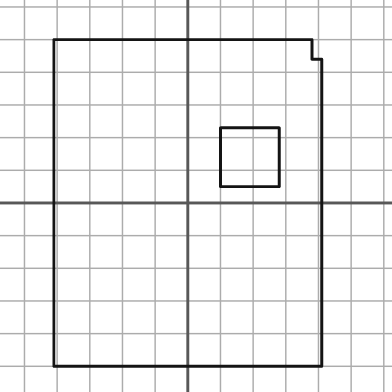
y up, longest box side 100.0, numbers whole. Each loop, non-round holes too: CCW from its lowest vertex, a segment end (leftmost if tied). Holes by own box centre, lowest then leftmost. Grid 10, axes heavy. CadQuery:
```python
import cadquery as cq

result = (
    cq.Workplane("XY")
    .moveTo(-41.0, -50.0)
    .lineTo(41.0, -50.0)
    .lineTo(41.0, 44.0)
    .lineTo(38.0, 44.0)
    .lineTo(38.0, 50.0)
    .lineTo(-41.0, 50.0)
    .close()
    .moveTo(10.0, 5.0)
    .lineTo(28.0, 5.0)
    .lineTo(28.0, 23.0)
    .lineTo(10.0, 23.0)
    .close()
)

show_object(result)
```